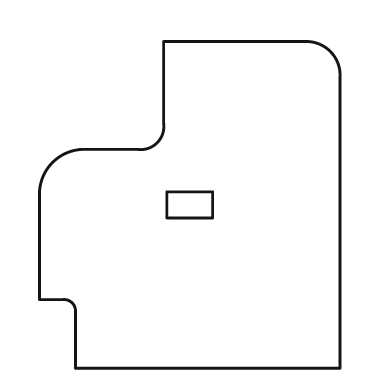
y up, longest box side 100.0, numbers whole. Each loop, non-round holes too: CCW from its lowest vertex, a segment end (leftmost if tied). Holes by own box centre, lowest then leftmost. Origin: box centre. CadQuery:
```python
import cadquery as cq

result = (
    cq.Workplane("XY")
    .moveTo(-35.0, -50.0)
    .lineTo(46.0, -50.0)
    .lineTo(46.0, 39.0)
    .threePointArc((43.0, 47.0), (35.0, 50.0))
    .lineTo(-8.0, 50.0)
    .lineTo(-8.0, 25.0)
    .threePointArc((-10.0, 19.0), (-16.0, 17.0))
    .lineTo(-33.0, 17.0)
    .threePointArc((-42.0, 13.0), (-46.0, 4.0))
    .lineTo(-46.0, -29.0)
    .lineTo(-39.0, -29.0)
    .threePointArc((-36.0, -30.0), (-35.0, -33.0))
    .close()
    .moveTo(-7.0, -4.0)
    .lineTo(7.0, -4.0)
    .lineTo(7.0, 4.0)
    .lineTo(-7.0, 4.0)
    .close()
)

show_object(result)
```